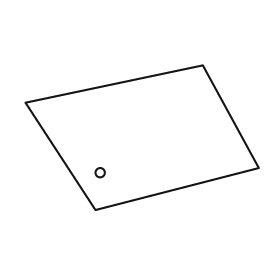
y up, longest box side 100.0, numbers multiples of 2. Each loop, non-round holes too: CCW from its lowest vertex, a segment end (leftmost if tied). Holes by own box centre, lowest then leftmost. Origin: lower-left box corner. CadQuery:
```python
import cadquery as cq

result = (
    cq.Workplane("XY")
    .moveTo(30.0, 0.0)
    .lineTo(100.0, 18.0)
    .lineTo(76.0, 62.0)
    .lineTo(0.0, 46.0)
    .close()
    .moveTo(32.0, 16.0)
    .circle(2.0)
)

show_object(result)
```